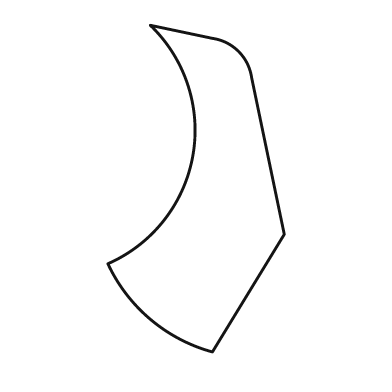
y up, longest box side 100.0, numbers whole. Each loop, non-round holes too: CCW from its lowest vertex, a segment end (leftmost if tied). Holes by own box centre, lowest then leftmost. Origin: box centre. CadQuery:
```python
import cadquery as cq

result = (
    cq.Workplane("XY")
    .moveTo(5.0, -50.0)
    .lineTo(27.0, -14.0)
    .lineTo(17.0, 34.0)
    .threePointArc((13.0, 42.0), (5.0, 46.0))
    .lineTo(-14.0, 50.0)
    .threePointArc((-1.0, 10.0), (-27.0, -23.0))
    .threePointArc((-14.0, -40.0), (5.0, -50.0))
    .close()
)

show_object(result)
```